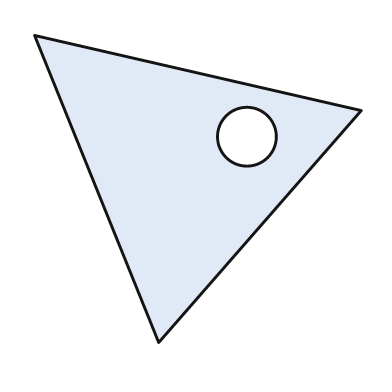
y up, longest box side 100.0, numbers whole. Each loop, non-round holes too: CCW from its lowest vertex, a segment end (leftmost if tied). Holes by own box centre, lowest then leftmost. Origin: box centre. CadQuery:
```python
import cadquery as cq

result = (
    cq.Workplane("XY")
    .moveTo(-12.0, -47.0)
    .lineTo(50.0, 24.0)
    .lineTo(-50.0, 47.0)
    .close()
    .moveTo(15.0, 16.0)
    .circle(9.0)
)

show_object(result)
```